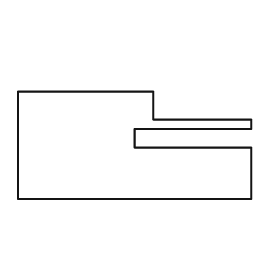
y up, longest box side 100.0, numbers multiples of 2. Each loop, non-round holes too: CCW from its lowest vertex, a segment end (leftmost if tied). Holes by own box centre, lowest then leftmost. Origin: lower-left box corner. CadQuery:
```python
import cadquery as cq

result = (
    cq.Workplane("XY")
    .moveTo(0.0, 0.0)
    .lineTo(100.0, 0.0)
    .lineTo(100.0, 22.0)
    .lineTo(50.0, 22.0)
    .lineTo(50.0, 30.0)
    .lineTo(100.0, 30.0)
    .lineTo(100.0, 34.0)
    .lineTo(58.0, 34.0)
    .lineTo(58.0, 46.0)
    .lineTo(0.0, 46.0)
    .close()
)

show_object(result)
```